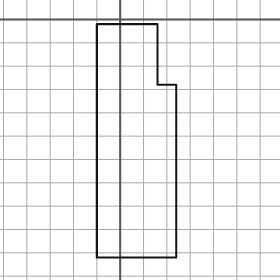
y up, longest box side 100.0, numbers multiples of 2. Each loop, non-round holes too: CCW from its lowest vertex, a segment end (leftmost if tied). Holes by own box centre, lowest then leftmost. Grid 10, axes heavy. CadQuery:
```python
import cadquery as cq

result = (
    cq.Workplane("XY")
    .moveTo(-10.0, -102.0)
    .lineTo(24.0, -102.0)
    .lineTo(24.0, -28.0)
    .lineTo(16.0, -28.0)
    .lineTo(16.0, -2.0)
    .lineTo(-10.0, -2.0)
    .close()
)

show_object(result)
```